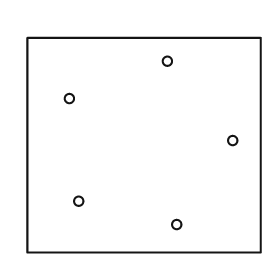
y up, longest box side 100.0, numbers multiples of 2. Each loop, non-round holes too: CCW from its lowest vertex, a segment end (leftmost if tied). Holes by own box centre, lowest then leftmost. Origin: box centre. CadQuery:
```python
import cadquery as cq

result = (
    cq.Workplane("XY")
    .moveTo(-50.0, -46.0)
    .lineTo(50.0, -46.0)
    .lineTo(50.0, 46.0)
    .lineTo(-50.0, 46.0)
    .close()
    .moveTo(14.0, -34.0)
    .circle(2.0)
    .moveTo(-28.0, -24.0)
    .circle(2.0)
    .moveTo(38.0, 2.0)
    .circle(2.0)
    .moveTo(-32.0, 20.0)
    .circle(2.0)
    .moveTo(10.0, 36.0)
    .circle(2.0)
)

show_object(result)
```